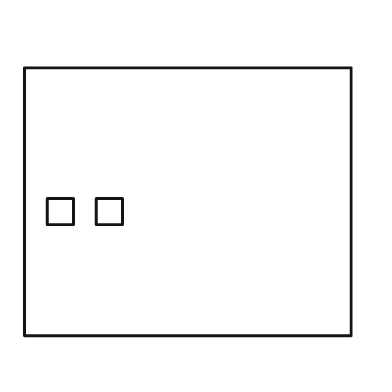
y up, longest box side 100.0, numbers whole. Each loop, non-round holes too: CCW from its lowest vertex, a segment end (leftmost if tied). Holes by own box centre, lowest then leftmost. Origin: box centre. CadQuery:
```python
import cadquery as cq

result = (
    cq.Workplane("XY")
    .moveTo(-50.0, -41.0)
    .lineTo(50.0, -41.0)
    .lineTo(50.0, 41.0)
    .lineTo(-50.0, 41.0)
    .close()
    .moveTo(-43.0, -7.0)
    .lineTo(-35.0, -7.0)
    .lineTo(-35.0, 1.0)
    .lineTo(-43.0, 1.0)
    .close()
    .moveTo(-28.0, -7.0)
    .lineTo(-20.0, -7.0)
    .lineTo(-20.0, 1.0)
    .lineTo(-28.0, 1.0)
    .close()
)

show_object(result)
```